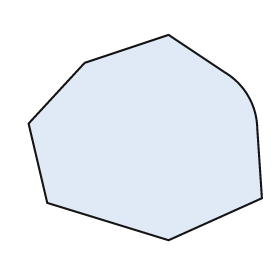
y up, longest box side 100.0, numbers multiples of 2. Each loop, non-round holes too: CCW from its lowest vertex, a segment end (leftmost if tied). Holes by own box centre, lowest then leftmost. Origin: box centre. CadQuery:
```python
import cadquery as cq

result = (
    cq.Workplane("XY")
    .moveTo(10.0, -44.0)
    .lineTo(50.0, -26.0)
    .lineTo(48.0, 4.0)
    .threePointArc((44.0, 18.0), (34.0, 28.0))
    .lineTo(10.0, 44.0)
    .lineTo(-26.0, 32.0)
    .lineTo(-50.0, 6.0)
    .lineTo(-42.0, -28.0)
    .close()
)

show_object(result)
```